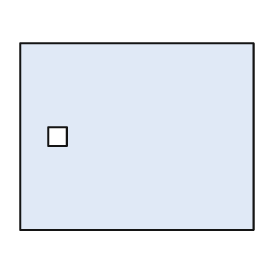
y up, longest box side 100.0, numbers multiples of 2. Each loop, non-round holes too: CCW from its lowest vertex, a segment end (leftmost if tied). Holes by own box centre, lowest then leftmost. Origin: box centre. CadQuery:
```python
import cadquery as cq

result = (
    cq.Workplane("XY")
    .moveTo(-50.0, -40.0)
    .lineTo(50.0, -40.0)
    .lineTo(50.0, 40.0)
    .lineTo(-50.0, 40.0)
    .close()
    .moveTo(-38.0, -4.0)
    .lineTo(-30.0, -4.0)
    .lineTo(-30.0, 4.0)
    .lineTo(-38.0, 4.0)
    .close()
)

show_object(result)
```